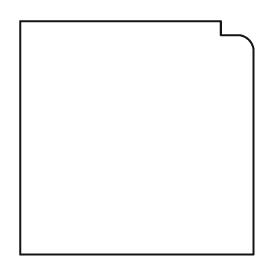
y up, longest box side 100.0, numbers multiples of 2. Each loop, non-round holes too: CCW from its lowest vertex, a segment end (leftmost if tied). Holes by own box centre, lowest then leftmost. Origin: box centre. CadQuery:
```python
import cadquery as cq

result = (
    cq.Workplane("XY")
    .moveTo(-50.0, -50.0)
    .lineTo(50.0, -50.0)
    .lineTo(50.0, 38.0)
    .threePointArc((48.0, 42.0), (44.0, 44.0))
    .lineTo(36.0, 44.0)
    .lineTo(36.0, 50.0)
    .lineTo(-50.0, 50.0)
    .close()
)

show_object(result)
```